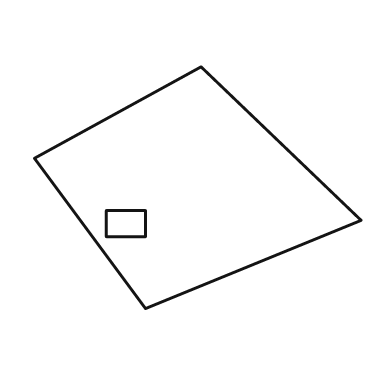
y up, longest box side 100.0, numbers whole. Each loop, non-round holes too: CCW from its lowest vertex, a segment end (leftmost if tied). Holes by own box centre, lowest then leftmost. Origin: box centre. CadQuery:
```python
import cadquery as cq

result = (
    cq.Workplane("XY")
    .moveTo(-16.0, -37.0)
    .lineTo(50.0, -10.0)
    .lineTo(1.0, 37.0)
    .lineTo(-50.0, 9.0)
    .close()
    .moveTo(-28.0, -15.0)
    .lineTo(-16.0, -15.0)
    .lineTo(-16.0, -7.0)
    .lineTo(-28.0, -7.0)
    .close()
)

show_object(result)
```